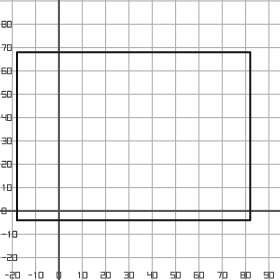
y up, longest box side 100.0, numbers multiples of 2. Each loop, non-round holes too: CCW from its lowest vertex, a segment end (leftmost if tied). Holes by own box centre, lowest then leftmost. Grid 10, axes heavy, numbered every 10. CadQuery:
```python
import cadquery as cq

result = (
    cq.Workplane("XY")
    .moveTo(-18.0, -4.0)
    .lineTo(82.0, -4.0)
    .lineTo(82.0, 68.0)
    .lineTo(-18.0, 68.0)
    .close()
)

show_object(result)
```